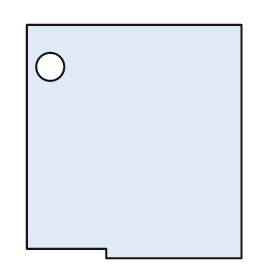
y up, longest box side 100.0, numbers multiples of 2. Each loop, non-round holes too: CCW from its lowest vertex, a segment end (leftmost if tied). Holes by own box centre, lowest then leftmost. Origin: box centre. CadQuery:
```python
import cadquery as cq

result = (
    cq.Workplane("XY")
    .moveTo(-12.0, -50.0)
    .lineTo(46.0, -50.0)
    .lineTo(46.0, 50.0)
    .lineTo(-46.0, 50.0)
    .lineTo(-46.0, -46.0)
    .lineTo(-12.0, -46.0)
    .close()
    .moveTo(-36.0, 32.0)
    .circle(6.0)
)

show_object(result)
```